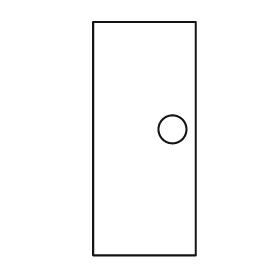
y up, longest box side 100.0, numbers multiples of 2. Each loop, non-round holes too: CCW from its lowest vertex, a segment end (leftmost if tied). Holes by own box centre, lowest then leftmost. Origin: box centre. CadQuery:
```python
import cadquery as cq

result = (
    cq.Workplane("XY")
    .moveTo(-22.0, -50.0)
    .lineTo(22.0, -50.0)
    .lineTo(22.0, 50.0)
    .lineTo(-22.0, 50.0)
    .close()
    .moveTo(12.0, 4.0)
    .circle(6.0)
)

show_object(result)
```